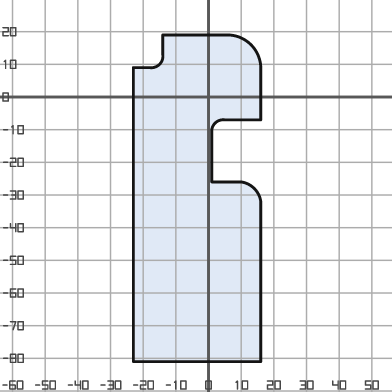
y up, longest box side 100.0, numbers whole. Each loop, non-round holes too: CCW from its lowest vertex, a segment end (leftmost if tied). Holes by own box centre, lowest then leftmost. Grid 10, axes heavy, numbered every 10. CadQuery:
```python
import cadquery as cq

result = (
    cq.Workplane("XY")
    .moveTo(-23.0, -81.0)
    .lineTo(16.0, -81.0)
    .lineTo(16.0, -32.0)
    .threePointArc((14.0, -28.0), (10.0, -26.0))
    .lineTo(1.0, -26.0)
    .lineTo(1.0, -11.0)
    .threePointArc((2.0, -8.0), (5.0, -7.0))
    .lineTo(16.0, -7.0)
    .lineTo(16.0, 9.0)
    .threePointArc((13.0, 16.0), (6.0, 19.0))
    .lineTo(-14.0, 19.0)
    .lineTo(-14.0, 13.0)
    .threePointArc((-15.0, 10.0), (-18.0, 9.0))
    .lineTo(-23.0, 9.0)
    .close()
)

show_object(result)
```